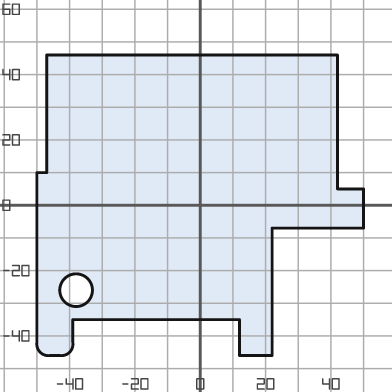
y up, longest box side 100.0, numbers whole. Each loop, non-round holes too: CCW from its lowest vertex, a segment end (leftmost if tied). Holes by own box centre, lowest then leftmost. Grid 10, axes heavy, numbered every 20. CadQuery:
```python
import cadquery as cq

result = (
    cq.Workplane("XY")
    .moveTo(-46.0, -46.0)
    .lineTo(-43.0, -46.0)
    .threePointArc((-40.0, -45.0), (-39.0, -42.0))
    .lineTo(-39.0, -35.0)
    .lineTo(12.0, -35.0)
    .lineTo(12.0, -46.0)
    .lineTo(22.0, -46.0)
    .lineTo(22.0, -7.0)
    .lineTo(50.0, -7.0)
    .lineTo(50.0, 5.0)
    .lineTo(42.0, 5.0)
    .lineTo(42.0, 46.0)
    .lineTo(-47.0, 46.0)
    .lineTo(-47.0, 10.0)
    .lineTo(-50.0, 10.0)
    .lineTo(-50.0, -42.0)
    .threePointArc((-49.0, -45.0), (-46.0, -46.0))
    .close()
    .moveTo(-38.0, -26.0)
    .circle(5.0)
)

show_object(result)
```